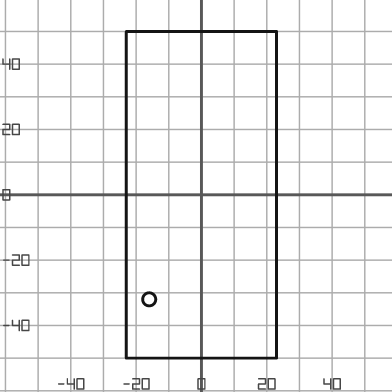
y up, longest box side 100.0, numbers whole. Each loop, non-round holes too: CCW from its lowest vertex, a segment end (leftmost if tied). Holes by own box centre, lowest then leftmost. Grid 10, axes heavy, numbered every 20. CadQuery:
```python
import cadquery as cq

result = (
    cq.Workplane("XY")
    .moveTo(-23.0, -50.0)
    .lineTo(23.0, -50.0)
    .lineTo(23.0, 50.0)
    .lineTo(-23.0, 50.0)
    .close()
    .moveTo(-16.0, -32.0)
    .circle(2.0)
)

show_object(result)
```